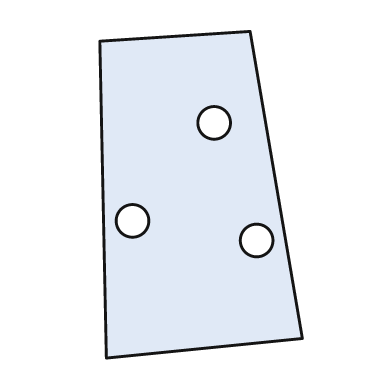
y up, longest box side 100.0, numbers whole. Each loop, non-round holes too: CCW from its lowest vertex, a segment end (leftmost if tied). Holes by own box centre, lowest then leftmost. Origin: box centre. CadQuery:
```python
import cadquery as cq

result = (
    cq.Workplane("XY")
    .moveTo(-29.0, -50.0)
    .lineTo(31.0, -44.0)
    .lineTo(15.0, 50.0)
    .lineTo(-31.0, 47.0)
    .close()
    .moveTo(17.0, -14.0)
    .circle(5.0)
    .moveTo(-21.0, -8.0)
    .circle(5.0)
    .moveTo(4.0, 22.0)
    .circle(5.0)
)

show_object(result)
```